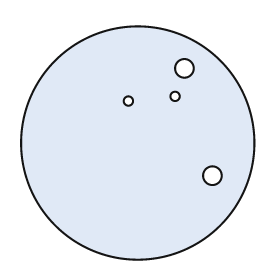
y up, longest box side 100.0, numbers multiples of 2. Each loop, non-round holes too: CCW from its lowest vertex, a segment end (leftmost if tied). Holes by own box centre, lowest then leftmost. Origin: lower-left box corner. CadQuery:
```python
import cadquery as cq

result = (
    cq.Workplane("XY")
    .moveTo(50.0, 50.0)
    .circle(50.0)
    .moveTo(82.0, 36.0)
    .circle(4.0)
    .moveTo(46.0, 68.0)
    .circle(2.0)
    .moveTo(66.0, 70.0)
    .circle(2.0)
    .moveTo(70.0, 82.0)
    .circle(4.0)
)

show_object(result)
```